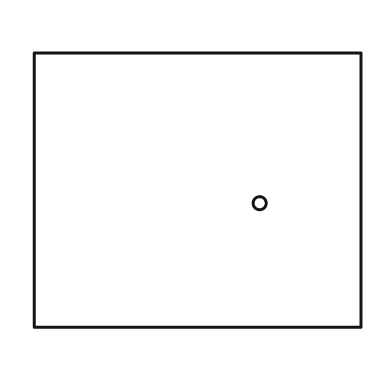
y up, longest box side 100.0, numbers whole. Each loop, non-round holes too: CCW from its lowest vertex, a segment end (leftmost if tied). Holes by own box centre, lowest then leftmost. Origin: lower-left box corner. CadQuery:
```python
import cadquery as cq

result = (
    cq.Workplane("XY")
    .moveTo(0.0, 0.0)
    .lineTo(100.0, 0.0)
    .lineTo(100.0, 84.0)
    .lineTo(0.0, 84.0)
    .close()
    .moveTo(69.0, 38.0)
    .circle(2.0)
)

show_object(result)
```